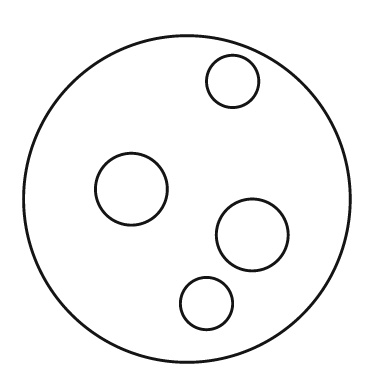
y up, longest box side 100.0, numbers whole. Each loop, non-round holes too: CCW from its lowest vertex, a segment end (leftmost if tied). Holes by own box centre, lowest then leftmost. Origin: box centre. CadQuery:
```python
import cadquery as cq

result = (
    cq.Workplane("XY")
    .moveTo(0.0, 0.0)
    .circle(50.0)
    .moveTo(6.0, -32.0)
    .circle(8.0)
    .moveTo(20.0, -11.0)
    .circle(11.0)
    .moveTo(-17.0, 3.0)
    .circle(11.0)
    .moveTo(14.0, 36.0)
    .circle(8.0)
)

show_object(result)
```